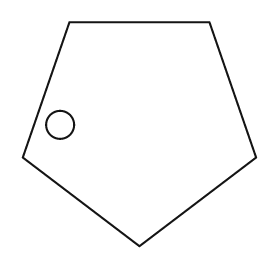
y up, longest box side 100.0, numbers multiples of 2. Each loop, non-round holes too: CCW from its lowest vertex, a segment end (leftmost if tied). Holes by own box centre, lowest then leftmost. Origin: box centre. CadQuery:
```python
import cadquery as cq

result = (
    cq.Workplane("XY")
    .moveTo(0.0, -48.0)
    .lineTo(50.0, -10.0)
    .lineTo(30.0, 48.0)
    .lineTo(-30.0, 48.0)
    .lineTo(-50.0, -10.0)
    .close()
    .moveTo(-34.0, 4.0)
    .circle(6.0)
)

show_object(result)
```